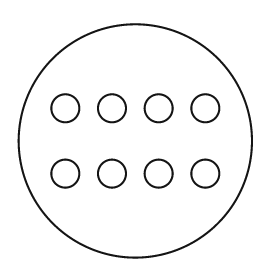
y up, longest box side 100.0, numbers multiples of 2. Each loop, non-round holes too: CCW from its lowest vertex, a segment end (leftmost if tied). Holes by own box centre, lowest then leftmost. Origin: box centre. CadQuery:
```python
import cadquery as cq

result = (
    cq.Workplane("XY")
    .moveTo(0.0, 0.0)
    .circle(50.0)
    .moveTo(-30.0, -14.0)
    .circle(6.0)
    .moveTo(-10.0, -14.0)
    .circle(6.0)
    .moveTo(10.0, -14.0)
    .circle(6.0)
    .moveTo(30.0, -14.0)
    .circle(6.0)
    .moveTo(-30.0, 14.0)
    .circle(6.0)
    .moveTo(-10.0, 14.0)
    .circle(6.0)
    .moveTo(10.0, 14.0)
    .circle(6.0)
    .moveTo(30.0, 14.0)
    .circle(6.0)
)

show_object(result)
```